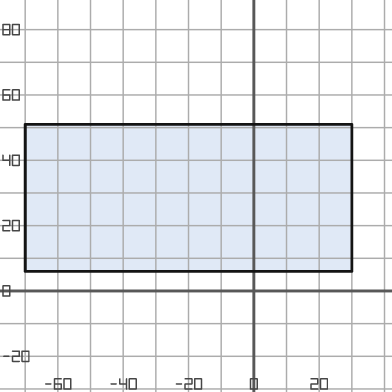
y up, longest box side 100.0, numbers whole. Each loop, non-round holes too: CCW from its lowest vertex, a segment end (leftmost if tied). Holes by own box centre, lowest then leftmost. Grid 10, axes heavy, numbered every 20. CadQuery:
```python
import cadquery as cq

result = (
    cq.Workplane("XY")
    .moveTo(-70.0, 6.0)
    .lineTo(30.0, 6.0)
    .lineTo(30.0, 51.0)
    .lineTo(-70.0, 51.0)
    .close()
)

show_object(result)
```